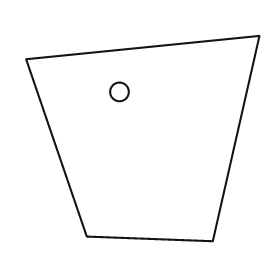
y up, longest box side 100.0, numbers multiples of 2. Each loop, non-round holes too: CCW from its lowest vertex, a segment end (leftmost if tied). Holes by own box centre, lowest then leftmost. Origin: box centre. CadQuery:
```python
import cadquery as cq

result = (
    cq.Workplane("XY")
    .moveTo(30.0, -44.0)
    .lineTo(50.0, 44.0)
    .lineTo(-50.0, 34.0)
    .lineTo(-24.0, -42.0)
    .close()
    .moveTo(-10.0, 20.0)
    .circle(4.0)
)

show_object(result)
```